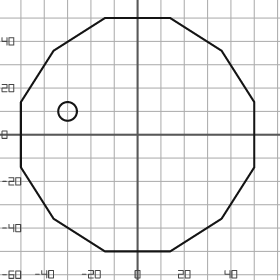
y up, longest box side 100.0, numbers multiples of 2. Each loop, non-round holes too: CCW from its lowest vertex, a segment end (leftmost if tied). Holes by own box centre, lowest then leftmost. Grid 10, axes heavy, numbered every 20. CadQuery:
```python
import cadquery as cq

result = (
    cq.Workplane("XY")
    .moveTo(-14.0, -50.0)
    .lineTo(14.0, -50.0)
    .lineTo(36.0, -36.0)
    .lineTo(50.0, -14.0)
    .lineTo(50.0, 14.0)
    .lineTo(36.0, 36.0)
    .lineTo(14.0, 50.0)
    .lineTo(-14.0, 50.0)
    .lineTo(-36.0, 36.0)
    .lineTo(-50.0, 14.0)
    .lineTo(-50.0, -14.0)
    .lineTo(-36.0, -36.0)
    .close()
    .moveTo(-30.0, 10.0)
    .circle(4.0)
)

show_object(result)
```